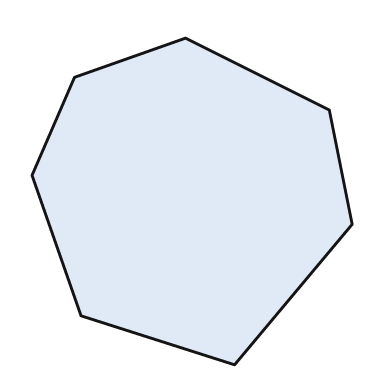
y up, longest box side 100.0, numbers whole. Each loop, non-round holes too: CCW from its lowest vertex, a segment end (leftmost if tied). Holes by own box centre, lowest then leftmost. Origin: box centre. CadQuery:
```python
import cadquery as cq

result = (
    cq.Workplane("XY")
    .moveTo(13.0, -50.0)
    .lineTo(49.0, -7.0)
    .lineTo(42.0, 28.0)
    .lineTo(-2.0, 50.0)
    .lineTo(-36.0, 38.0)
    .lineTo(-49.0, 8.0)
    .lineTo(-34.0, -35.0)
    .close()
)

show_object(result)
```